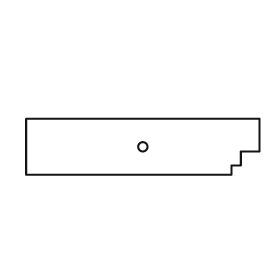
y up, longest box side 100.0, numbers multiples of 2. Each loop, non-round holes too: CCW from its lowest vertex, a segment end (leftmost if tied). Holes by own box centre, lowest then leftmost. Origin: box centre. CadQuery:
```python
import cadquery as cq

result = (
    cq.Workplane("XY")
    .moveTo(-50.0, -12.0)
    .lineTo(38.0, -12.0)
    .lineTo(38.0, -8.0)
    .lineTo(42.0, -8.0)
    .lineTo(42.0, -2.0)
    .lineTo(50.0, -2.0)
    .lineTo(50.0, 12.0)
    .lineTo(-50.0, 12.0)
    .close()
    .moveTo(0.0, 0.0)
    .circle(2.0)
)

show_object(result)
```